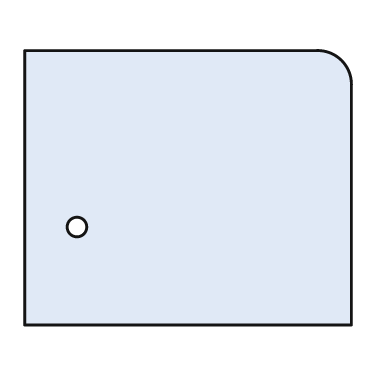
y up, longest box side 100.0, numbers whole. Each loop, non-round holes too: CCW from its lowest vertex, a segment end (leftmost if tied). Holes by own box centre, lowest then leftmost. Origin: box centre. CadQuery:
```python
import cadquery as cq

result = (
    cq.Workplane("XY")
    .moveTo(-50.0, -42.0)
    .lineTo(50.0, -42.0)
    .lineTo(50.0, 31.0)
    .threePointArc((47.0, 39.0), (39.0, 42.0))
    .lineTo(-50.0, 42.0)
    .close()
    .moveTo(-34.0, -12.0)
    .circle(3.0)
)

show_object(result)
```